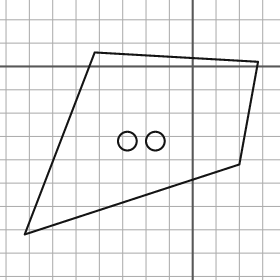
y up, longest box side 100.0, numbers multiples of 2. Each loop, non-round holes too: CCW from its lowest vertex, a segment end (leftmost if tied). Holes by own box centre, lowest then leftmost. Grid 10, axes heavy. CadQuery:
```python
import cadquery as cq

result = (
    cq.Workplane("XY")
    .moveTo(-72.0, -72.0)
    .lineTo(20.0, -42.0)
    .lineTo(28.0, 2.0)
    .lineTo(-42.0, 6.0)
    .close()
    .moveTo(-28.0, -32.0)
    .circle(4.0)
    .moveTo(-16.0, -32.0)
    .circle(4.0)
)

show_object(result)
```